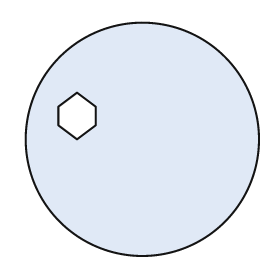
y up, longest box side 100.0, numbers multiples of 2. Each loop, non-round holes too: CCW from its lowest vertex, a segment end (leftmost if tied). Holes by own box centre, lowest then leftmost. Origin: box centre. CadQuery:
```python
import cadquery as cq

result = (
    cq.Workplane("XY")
    .moveTo(0.0, 0.0)
    .circle(50.0)
    .moveTo(-28.0, 0.0)
    .lineTo(-20.0, 6.0)
    .lineTo(-20.0, 14.0)
    .lineTo(-28.0, 20.0)
    .lineTo(-36.0, 14.0)
    .lineTo(-36.0, 6.0)
    .close()
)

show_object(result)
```